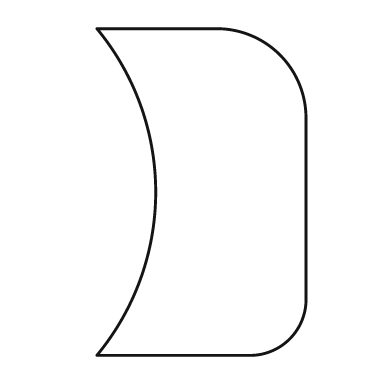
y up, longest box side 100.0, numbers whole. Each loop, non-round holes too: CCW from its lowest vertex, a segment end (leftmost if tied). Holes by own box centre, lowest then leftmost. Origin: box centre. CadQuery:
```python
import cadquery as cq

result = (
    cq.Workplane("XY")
    .moveTo(-32.0, -50.0)
    .lineTo(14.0, -50.0)
    .threePointArc((27.0, -45.0), (32.0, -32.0))
    .lineTo(32.0, 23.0)
    .threePointArc((24.0, 42.0), (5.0, 50.0))
    .lineTo(-32.0, 50.0)
    .threePointArc((-14.0, 0.0), (-32.0, -50.0))
    .close()
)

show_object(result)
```